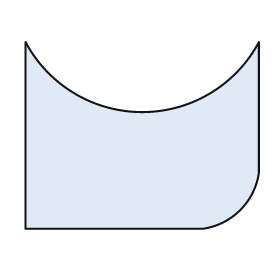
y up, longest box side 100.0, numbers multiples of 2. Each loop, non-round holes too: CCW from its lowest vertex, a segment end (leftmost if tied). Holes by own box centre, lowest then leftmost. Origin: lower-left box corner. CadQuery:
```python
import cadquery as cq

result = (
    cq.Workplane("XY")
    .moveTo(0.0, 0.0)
    .lineTo(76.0, 0.0)
    .threePointArc((92.0, 8.0), (100.0, 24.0))
    .lineTo(100.0, 80.0)
    .threePointArc((50.0, 50.0), (0.0, 80.0))
    .close()
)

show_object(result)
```